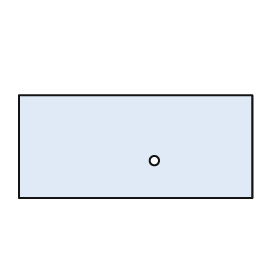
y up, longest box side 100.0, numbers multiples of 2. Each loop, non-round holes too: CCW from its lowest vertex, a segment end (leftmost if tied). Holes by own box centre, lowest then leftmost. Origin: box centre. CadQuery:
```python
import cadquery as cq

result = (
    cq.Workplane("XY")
    .moveTo(-50.0, -22.0)
    .lineTo(50.0, -22.0)
    .lineTo(50.0, 22.0)
    .lineTo(-50.0, 22.0)
    .close()
    .moveTo(8.0, -6.0)
    .circle(2.0)
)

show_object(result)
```